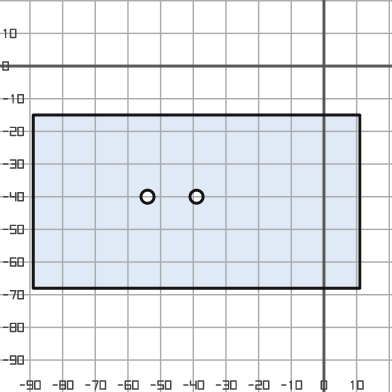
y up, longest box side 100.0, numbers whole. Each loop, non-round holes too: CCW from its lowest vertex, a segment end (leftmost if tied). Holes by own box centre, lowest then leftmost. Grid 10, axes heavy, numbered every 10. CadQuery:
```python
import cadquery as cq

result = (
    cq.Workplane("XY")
    .moveTo(-89.0, -68.0)
    .lineTo(11.0, -68.0)
    .lineTo(11.0, -15.0)
    .lineTo(-89.0, -15.0)
    .close()
    .moveTo(-54.0, -40.0)
    .circle(2.0)
    .moveTo(-39.0, -40.0)
    .circle(2.0)
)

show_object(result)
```